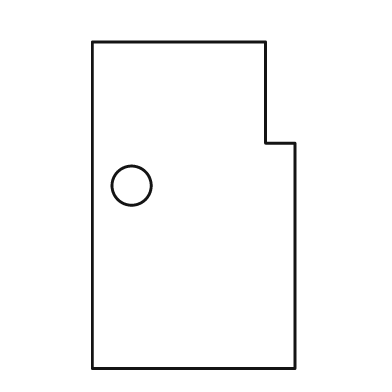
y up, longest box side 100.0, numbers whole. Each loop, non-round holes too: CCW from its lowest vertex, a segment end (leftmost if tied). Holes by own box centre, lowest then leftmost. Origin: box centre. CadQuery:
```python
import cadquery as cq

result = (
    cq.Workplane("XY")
    .moveTo(-31.0, -50.0)
    .lineTo(31.0, -50.0)
    .lineTo(31.0, 19.0)
    .lineTo(22.0, 19.0)
    .lineTo(22.0, 50.0)
    .lineTo(-31.0, 50.0)
    .close()
    .moveTo(-19.0, 6.0)
    .circle(6.0)
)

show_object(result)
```